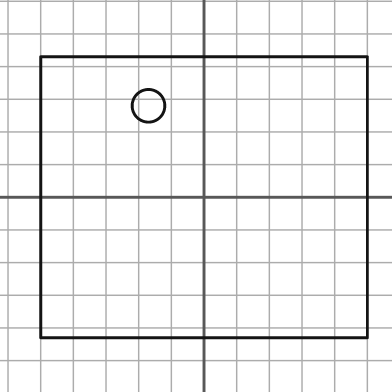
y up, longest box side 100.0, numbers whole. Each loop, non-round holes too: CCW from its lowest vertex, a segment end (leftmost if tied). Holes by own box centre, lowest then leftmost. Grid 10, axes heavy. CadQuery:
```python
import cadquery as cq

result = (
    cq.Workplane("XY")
    .moveTo(-50.0, -43.0)
    .lineTo(50.0, -43.0)
    .lineTo(50.0, 43.0)
    .lineTo(-50.0, 43.0)
    .close()
    .moveTo(-17.0, 28.0)
    .circle(5.0)
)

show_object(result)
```